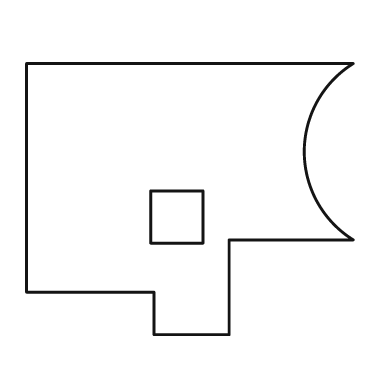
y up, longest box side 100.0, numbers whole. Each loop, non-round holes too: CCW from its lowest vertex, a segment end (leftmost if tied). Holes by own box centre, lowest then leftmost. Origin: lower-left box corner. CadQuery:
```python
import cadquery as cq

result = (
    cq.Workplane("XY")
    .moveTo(39.0, 0.0)
    .lineTo(62.0, 0.0)
    .lineTo(62.0, 29.0)
    .lineTo(100.0, 29.0)
    .threePointArc((85.0, 56.0), (100.0, 83.0))
    .lineTo(0.0, 83.0)
    .lineTo(0.0, 13.0)
    .lineTo(39.0, 13.0)
    .close()
    .moveTo(38.0, 28.0)
    .lineTo(54.0, 28.0)
    .lineTo(54.0, 44.0)
    .lineTo(38.0, 44.0)
    .close()
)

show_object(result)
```